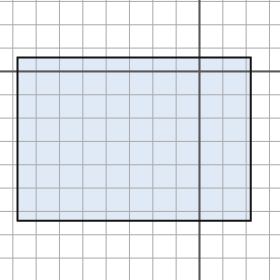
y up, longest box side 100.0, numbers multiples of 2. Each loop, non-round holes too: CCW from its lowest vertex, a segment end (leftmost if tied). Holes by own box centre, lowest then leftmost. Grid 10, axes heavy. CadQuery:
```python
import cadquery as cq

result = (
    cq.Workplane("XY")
    .moveTo(-78.0, -64.0)
    .lineTo(22.0, -64.0)
    .lineTo(22.0, 6.0)
    .lineTo(-78.0, 6.0)
    .close()
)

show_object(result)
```